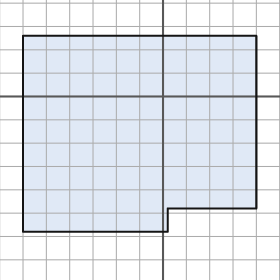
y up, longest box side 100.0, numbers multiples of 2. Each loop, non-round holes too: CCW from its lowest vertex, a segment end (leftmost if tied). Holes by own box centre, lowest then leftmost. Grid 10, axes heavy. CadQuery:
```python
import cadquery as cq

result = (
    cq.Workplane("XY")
    .moveTo(-60.0, -58.0)
    .lineTo(2.0, -58.0)
    .lineTo(2.0, -48.0)
    .lineTo(40.0, -48.0)
    .lineTo(40.0, 26.0)
    .lineTo(-60.0, 26.0)
    .close()
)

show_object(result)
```